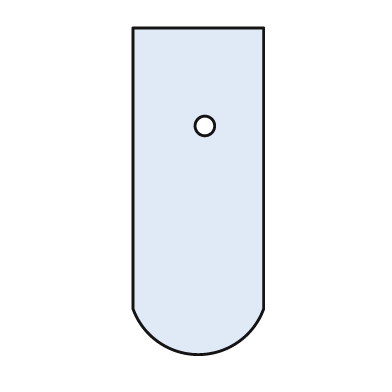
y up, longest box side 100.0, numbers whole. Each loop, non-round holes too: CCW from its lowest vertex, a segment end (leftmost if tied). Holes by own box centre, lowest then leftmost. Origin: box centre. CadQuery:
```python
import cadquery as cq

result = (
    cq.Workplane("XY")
    .moveTo(-20.0, -36.0)
    .threePointArc((0.0, -50.0), (20.0, -36.0))
    .lineTo(20.0, 50.0)
    .lineTo(-20.0, 50.0)
    .close()
    .moveTo(2.0, 20.0)
    .circle(3.0)
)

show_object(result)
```